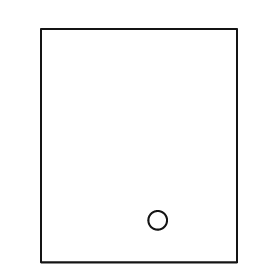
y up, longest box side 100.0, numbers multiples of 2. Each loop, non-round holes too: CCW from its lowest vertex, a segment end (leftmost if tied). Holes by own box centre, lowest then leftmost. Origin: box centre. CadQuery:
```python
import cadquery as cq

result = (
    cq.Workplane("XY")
    .moveTo(-42.0, -50.0)
    .lineTo(42.0, -50.0)
    .lineTo(42.0, 50.0)
    .lineTo(-42.0, 50.0)
    .close()
    .moveTo(8.0, -32.0)
    .circle(4.0)
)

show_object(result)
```